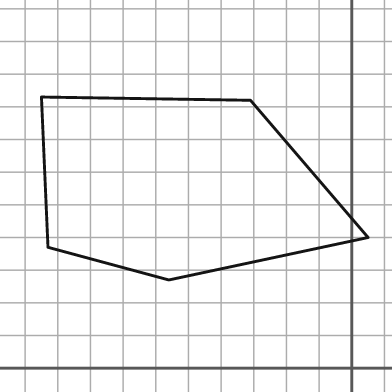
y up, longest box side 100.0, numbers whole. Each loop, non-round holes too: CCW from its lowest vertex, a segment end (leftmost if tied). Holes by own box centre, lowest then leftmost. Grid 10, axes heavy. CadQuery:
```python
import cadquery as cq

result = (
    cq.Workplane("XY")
    .moveTo(-56.0, 27.0)
    .lineTo(5.0, 40.0)
    .lineTo(-31.0, 82.0)
    .lineTo(-95.0, 83.0)
    .lineTo(-93.0, 37.0)
    .close()
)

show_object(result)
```